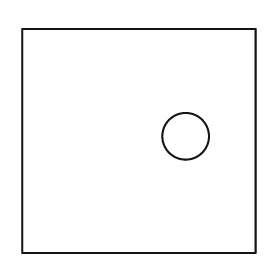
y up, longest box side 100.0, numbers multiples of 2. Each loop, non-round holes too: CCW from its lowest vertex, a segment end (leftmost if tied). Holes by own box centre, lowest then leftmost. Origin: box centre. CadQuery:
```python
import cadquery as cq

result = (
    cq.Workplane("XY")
    .moveTo(-50.0, -48.0)
    .lineTo(50.0, -48.0)
    .lineTo(50.0, 48.0)
    .lineTo(-50.0, 48.0)
    .close()
    .moveTo(20.0, 2.0)
    .circle(10.0)
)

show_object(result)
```